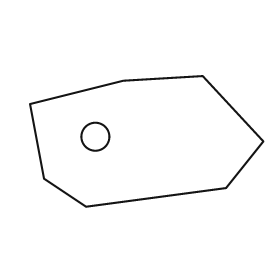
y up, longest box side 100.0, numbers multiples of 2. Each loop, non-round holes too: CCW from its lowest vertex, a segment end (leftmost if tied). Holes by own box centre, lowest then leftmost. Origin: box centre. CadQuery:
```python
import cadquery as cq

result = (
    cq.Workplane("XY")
    .moveTo(-26.0, -28.0)
    .lineTo(34.0, -20.0)
    .lineTo(50.0, 0.0)
    .lineTo(24.0, 28.0)
    .lineTo(-10.0, 26.0)
    .lineTo(-50.0, 16.0)
    .lineTo(-44.0, -16.0)
    .close()
    .moveTo(-22.0, 2.0)
    .circle(6.0)
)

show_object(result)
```